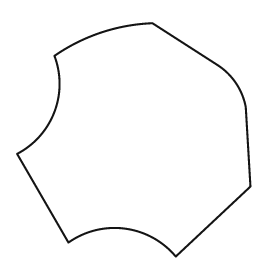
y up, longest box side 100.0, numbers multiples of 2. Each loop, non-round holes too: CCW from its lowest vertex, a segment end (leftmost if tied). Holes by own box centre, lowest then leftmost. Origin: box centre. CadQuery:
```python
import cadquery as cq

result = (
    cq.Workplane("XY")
    .moveTo(18.0, -50.0)
    .lineTo(50.0, -20.0)
    .lineTo(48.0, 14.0)
    .threePointArc((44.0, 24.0), (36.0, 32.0))
    .lineTo(8.0, 50.0)
    .threePointArc((-14.0, 46.0), (-34.0, 36.0))
    .threePointArc((-34.0, 12.0), (-50.0, -6.0))
    .lineTo(-28.0, -44.0)
    .threePointArc((-4.0, -38.0), (18.0, -50.0))
    .close()
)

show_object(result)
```